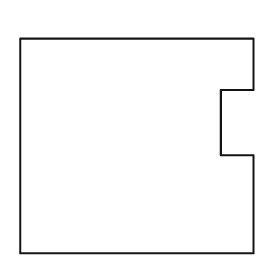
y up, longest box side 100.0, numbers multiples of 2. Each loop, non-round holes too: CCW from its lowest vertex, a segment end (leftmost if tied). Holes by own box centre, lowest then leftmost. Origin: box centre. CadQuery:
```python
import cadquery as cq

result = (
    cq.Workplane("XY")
    .moveTo(-50.0, -46.0)
    .lineTo(50.0, -46.0)
    .lineTo(50.0, -4.0)
    .lineTo(36.0, -4.0)
    .lineTo(36.0, 24.0)
    .lineTo(50.0, 24.0)
    .lineTo(50.0, 46.0)
    .lineTo(-50.0, 46.0)
    .close()
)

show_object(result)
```